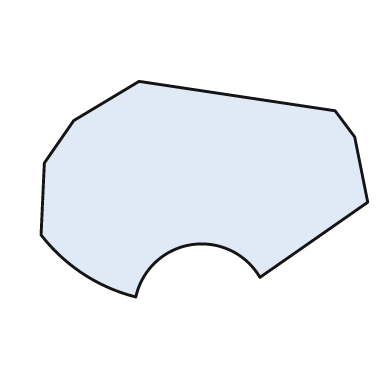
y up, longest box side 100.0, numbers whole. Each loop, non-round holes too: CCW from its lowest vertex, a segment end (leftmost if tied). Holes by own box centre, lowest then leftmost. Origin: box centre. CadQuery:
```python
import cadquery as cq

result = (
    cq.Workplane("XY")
    .moveTo(-21.0, -33.0)
    .threePointArc((-4.0, -17.0), (17.0, -27.0))
    .lineTo(50.0, -4.0)
    .lineTo(46.0, 16.0)
    .lineTo(40.0, 24.0)
    .lineTo(-20.0, 33.0)
    .lineTo(-40.0, 21.0)
    .lineTo(-49.0, 8.0)
    .lineTo(-50.0, -14.0)
    .threePointArc((-37.0, -26.0), (-21.0, -33.0))
    .close()
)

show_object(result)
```